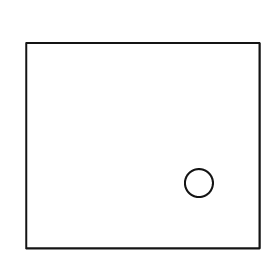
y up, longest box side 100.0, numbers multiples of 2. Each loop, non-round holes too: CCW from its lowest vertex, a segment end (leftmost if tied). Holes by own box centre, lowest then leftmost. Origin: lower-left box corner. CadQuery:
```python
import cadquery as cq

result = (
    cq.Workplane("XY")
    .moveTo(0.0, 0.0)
    .lineTo(100.0, 0.0)
    .lineTo(100.0, 88.0)
    .lineTo(0.0, 88.0)
    .close()
    .moveTo(74.0, 28.0)
    .circle(6.0)
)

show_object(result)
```